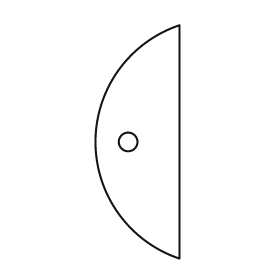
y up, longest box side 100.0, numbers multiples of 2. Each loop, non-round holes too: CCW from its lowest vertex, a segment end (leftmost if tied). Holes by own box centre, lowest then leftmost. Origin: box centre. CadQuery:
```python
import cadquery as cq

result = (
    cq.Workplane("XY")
    .moveTo(18.0, -50.0)
    .lineTo(18.0, 50.0)
    .threePointArc((-18.0, 0.0), (18.0, -50.0))
    .close()
    .moveTo(-4.0, 0.0)
    .circle(4.0)
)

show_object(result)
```